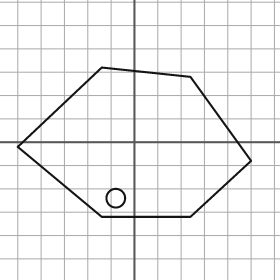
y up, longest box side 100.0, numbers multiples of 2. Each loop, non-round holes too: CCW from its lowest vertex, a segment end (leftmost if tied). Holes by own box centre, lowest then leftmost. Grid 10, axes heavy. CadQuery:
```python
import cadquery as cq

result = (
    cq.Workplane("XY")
    .moveTo(-14.0, -32.0)
    .lineTo(24.0, -32.0)
    .lineTo(50.0, -8.0)
    .lineTo(24.0, 28.0)
    .lineTo(-14.0, 32.0)
    .lineTo(-50.0, -2.0)
    .close()
    .moveTo(-8.0, -24.0)
    .circle(4.0)
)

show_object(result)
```